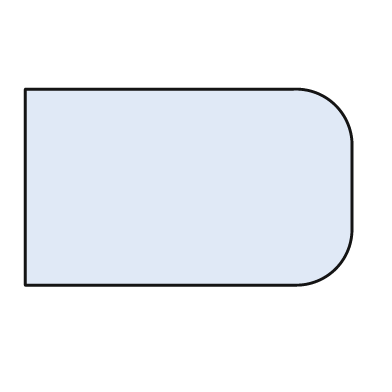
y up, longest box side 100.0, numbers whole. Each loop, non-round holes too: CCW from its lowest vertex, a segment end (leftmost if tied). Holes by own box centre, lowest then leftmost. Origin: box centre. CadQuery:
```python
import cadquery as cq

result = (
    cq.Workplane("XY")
    .moveTo(-50.0, -30.0)
    .lineTo(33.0, -30.0)
    .threePointArc((45.0, -25.0), (50.0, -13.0))
    .lineTo(50.0, 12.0)
    .threePointArc((45.0, 25.0), (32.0, 30.0))
    .lineTo(-50.0, 30.0)
    .close()
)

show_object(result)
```